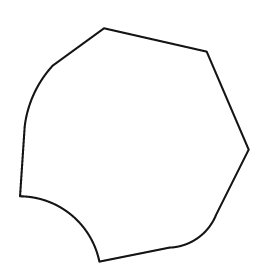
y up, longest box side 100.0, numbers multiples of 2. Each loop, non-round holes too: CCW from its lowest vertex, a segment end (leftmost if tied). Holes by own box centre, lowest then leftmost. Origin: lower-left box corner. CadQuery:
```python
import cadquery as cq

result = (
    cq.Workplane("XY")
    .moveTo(34.0, 0.0)
    .lineTo(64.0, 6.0)
    .threePointArc((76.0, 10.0), (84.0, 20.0))
    .lineTo(98.0, 48.0)
    .lineTo(80.0, 90.0)
    .lineTo(36.0, 100.0)
    .lineTo(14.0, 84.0)
    .threePointArc((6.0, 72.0), (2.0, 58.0))
    .lineTo(0.0, 28.0)
    .threePointArc((22.0, 20.0), (34.0, 0.0))
    .close()
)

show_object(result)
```